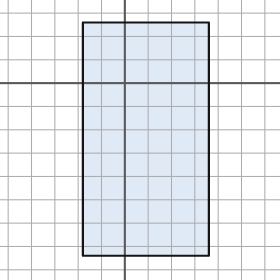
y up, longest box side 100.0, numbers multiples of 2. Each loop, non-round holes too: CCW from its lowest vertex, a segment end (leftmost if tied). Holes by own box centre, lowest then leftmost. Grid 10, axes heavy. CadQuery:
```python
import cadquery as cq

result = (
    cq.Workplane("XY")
    .moveTo(-18.0, -74.0)
    .lineTo(36.0, -74.0)
    .lineTo(36.0, 26.0)
    .lineTo(-18.0, 26.0)
    .close()
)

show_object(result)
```